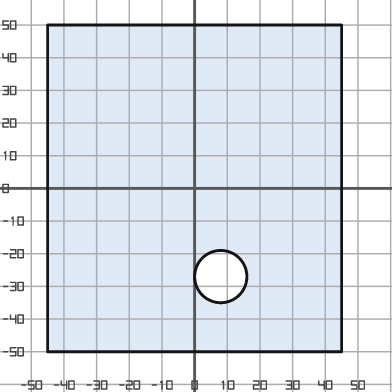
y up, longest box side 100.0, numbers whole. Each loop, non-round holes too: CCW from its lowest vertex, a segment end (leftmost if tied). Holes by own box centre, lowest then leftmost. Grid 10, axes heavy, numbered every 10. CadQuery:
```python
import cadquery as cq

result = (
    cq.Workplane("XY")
    .moveTo(-45.0, -50.0)
    .lineTo(45.0, -50.0)
    .lineTo(45.0, 50.0)
    .lineTo(-45.0, 50.0)
    .close()
    .moveTo(8.0, -27.0)
    .circle(8.0)
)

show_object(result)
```